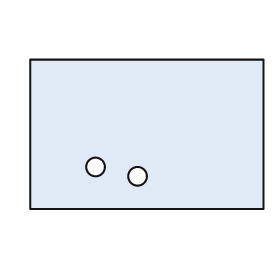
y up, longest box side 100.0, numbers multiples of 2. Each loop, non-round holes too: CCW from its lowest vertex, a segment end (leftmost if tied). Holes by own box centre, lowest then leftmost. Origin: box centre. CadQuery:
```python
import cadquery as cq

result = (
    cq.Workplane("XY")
    .moveTo(-50.0, -32.0)
    .lineTo(50.0, -32.0)
    .lineTo(50.0, 32.0)
    .lineTo(-50.0, 32.0)
    .close()
    .moveTo(-4.0, -18.0)
    .circle(4.0)
    .moveTo(-22.0, -14.0)
    .circle(4.0)
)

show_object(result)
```